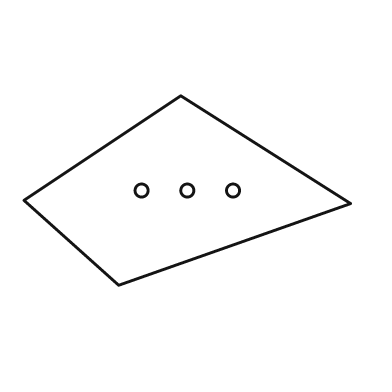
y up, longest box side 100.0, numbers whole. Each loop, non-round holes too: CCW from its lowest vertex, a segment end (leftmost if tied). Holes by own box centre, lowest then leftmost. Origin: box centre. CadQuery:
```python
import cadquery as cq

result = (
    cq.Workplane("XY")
    .moveTo(-21.0, -29.0)
    .lineTo(50.0, -4.0)
    .lineTo(-2.0, 29.0)
    .lineTo(-50.0, -3.0)
    .close()
    .moveTo(-14.0, 0.0)
    .circle(2.0)
    .moveTo(0.0, 0.0)
    .circle(2.0)
    .moveTo(14.0, 0.0)
    .circle(2.0)
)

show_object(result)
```